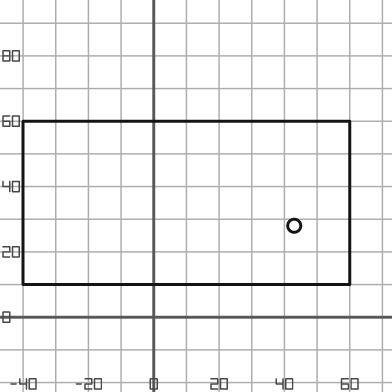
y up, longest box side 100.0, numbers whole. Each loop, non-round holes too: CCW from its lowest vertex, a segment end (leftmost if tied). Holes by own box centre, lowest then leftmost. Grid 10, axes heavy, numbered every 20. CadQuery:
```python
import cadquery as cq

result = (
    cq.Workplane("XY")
    .moveTo(-40.0, 10.0)
    .lineTo(60.0, 10.0)
    .lineTo(60.0, 60.0)
    .lineTo(-40.0, 60.0)
    .close()
    .moveTo(43.0, 28.0)
    .circle(2.0)
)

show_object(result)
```